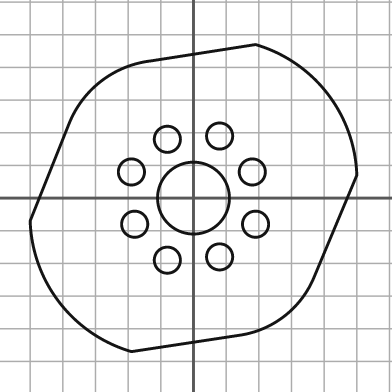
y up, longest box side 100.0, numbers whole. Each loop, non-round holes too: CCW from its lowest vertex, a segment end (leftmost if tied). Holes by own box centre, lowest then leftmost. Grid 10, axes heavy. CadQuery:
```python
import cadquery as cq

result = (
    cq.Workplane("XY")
    .moveTo(-19.0, -47.0)
    .lineTo(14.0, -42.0)
    .threePointArc((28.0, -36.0), (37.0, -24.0))
    .lineTo(50.0, 7.0)
    .threePointArc((41.0, 32.0), (19.0, 47.0))
    .lineTo(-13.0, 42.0)
    .threePointArc((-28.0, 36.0), (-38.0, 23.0))
    .lineTo(-50.0, -7.0)
    .threePointArc((-41.0, -32.0), (-19.0, -47.0))
    .close()
    .moveTo(-8.0, -19.0)
    .circle(4.0)
    .moveTo(8.0, -18.0)
    .circle(4.0)
    .moveTo(-18.0, -8.0)
    .circle(4.0)
    .moveTo(19.0, -8.0)
    .circle(4.0)
    .moveTo(0.0, 0.0)
    .circle(11.0)
    .moveTo(-19.0, 8.0)
    .circle(4.0)
    .moveTo(18.0, 8.0)
    .circle(4.0)
    .moveTo(-8.0, 18.0)
    .circle(4.0)
    .moveTo(8.0, 19.0)
    .circle(4.0)
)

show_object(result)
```